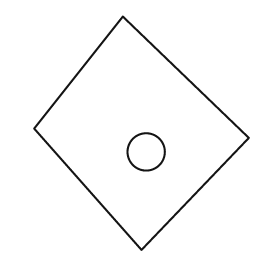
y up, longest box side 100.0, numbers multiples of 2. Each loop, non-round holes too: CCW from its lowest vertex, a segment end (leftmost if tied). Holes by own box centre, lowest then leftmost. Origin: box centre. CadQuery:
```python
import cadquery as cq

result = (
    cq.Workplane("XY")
    .moveTo(0.0, -50.0)
    .lineTo(46.0, -2.0)
    .lineTo(-8.0, 50.0)
    .lineTo(-46.0, 2.0)
    .close()
    .moveTo(2.0, -8.0)
    .circle(8.0)
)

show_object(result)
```